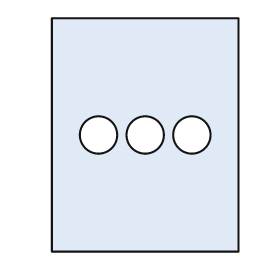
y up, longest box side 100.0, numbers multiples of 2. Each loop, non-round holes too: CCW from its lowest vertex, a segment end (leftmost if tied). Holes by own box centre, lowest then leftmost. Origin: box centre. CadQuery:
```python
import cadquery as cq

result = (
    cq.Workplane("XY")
    .moveTo(-40.0, -50.0)
    .lineTo(40.0, -50.0)
    .lineTo(40.0, 50.0)
    .lineTo(-40.0, 50.0)
    .close()
    .moveTo(-20.0, 0.0)
    .circle(8.0)
    .moveTo(0.0, 0.0)
    .circle(8.0)
    .moveTo(20.0, 0.0)
    .circle(8.0)
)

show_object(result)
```